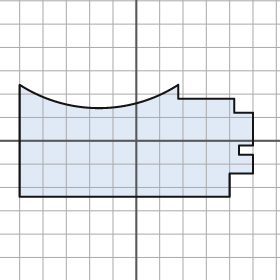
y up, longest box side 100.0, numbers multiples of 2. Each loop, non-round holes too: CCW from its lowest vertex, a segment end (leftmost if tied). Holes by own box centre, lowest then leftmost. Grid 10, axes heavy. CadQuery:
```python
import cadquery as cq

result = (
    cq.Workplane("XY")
    .moveTo(-50.0, -24.0)
    .lineTo(40.0, -24.0)
    .lineTo(40.0, -14.0)
    .lineTo(50.0, -14.0)
    .lineTo(50.0, -6.0)
    .lineTo(44.0, -6.0)
    .lineTo(44.0, -2.0)
    .lineTo(50.0, -2.0)
    .lineTo(50.0, 12.0)
    .lineTo(42.0, 12.0)
    .lineTo(42.0, 18.0)
    .lineTo(18.0, 18.0)
    .lineTo(18.0, 24.0)
    .threePointArc((-16.0, 14.0), (-50.0, 24.0))
    .close()
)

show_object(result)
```